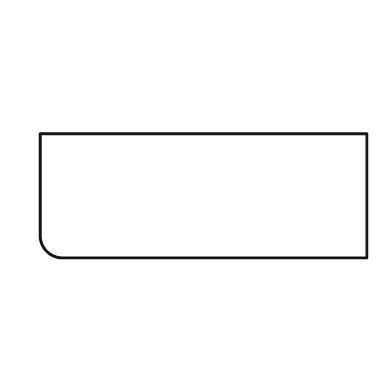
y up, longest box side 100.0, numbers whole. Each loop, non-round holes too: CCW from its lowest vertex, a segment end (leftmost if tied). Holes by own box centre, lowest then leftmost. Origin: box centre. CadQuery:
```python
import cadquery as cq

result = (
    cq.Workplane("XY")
    .moveTo(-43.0, -19.0)
    .lineTo(50.0, -19.0)
    .lineTo(50.0, 19.0)
    .lineTo(-50.0, 19.0)
    .lineTo(-50.0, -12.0)
    .threePointArc((-48.0, -17.0), (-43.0, -19.0))
    .close()
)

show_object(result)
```